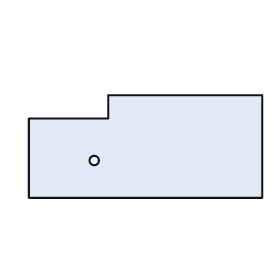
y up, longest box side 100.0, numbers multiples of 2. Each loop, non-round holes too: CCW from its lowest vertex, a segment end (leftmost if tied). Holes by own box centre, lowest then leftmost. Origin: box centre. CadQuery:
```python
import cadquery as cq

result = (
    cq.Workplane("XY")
    .moveTo(-50.0, -22.0)
    .lineTo(50.0, -22.0)
    .lineTo(50.0, 22.0)
    .lineTo(-16.0, 22.0)
    .lineTo(-16.0, 12.0)
    .lineTo(-50.0, 12.0)
    .close()
    .moveTo(-22.0, -6.0)
    .circle(2.0)
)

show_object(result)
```